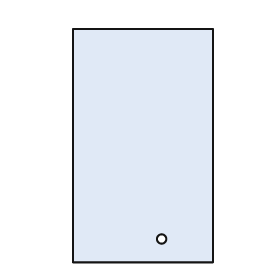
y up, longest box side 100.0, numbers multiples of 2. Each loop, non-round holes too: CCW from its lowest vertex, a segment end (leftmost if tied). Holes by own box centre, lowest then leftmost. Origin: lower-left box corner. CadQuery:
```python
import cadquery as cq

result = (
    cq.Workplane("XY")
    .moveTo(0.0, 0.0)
    .lineTo(60.0, 0.0)
    .lineTo(60.0, 100.0)
    .lineTo(0.0, 100.0)
    .close()
    .moveTo(38.0, 10.0)
    .circle(2.0)
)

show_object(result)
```